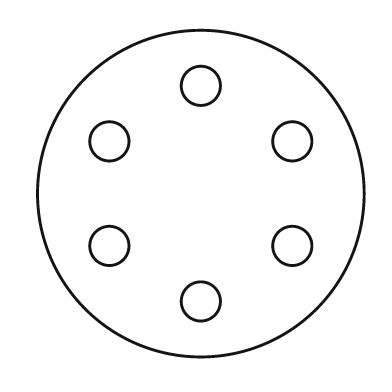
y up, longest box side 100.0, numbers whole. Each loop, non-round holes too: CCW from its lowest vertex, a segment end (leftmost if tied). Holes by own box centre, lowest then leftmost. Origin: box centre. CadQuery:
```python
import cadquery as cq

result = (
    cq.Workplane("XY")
    .moveTo(0.0, 0.0)
    .circle(50.0)
    .moveTo(0.0, -33.0)
    .circle(6.0)
    .moveTo(-28.0, -16.0)
    .circle(6.0)
    .moveTo(28.0, -16.0)
    .circle(6.0)
    .moveTo(-28.0, 16.0)
    .circle(6.0)
    .moveTo(28.0, 16.0)
    .circle(6.0)
    .moveTo(0.0, 33.0)
    .circle(6.0)
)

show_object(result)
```